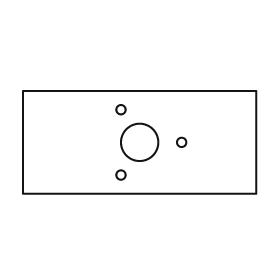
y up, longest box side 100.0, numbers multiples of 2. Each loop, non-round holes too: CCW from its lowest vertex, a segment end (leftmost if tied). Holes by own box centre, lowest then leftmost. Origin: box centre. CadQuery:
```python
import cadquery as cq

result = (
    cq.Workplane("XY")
    .moveTo(-50.0, -22.0)
    .lineTo(50.0, -22.0)
    .lineTo(50.0, 22.0)
    .lineTo(-50.0, 22.0)
    .close()
    .moveTo(-8.0, -14.0)
    .circle(2.0)
    .moveTo(0.0, 0.0)
    .circle(8.0)
    .moveTo(18.0, 0.0)
    .circle(2.0)
    .moveTo(-8.0, 14.0)
    .circle(2.0)
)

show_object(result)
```